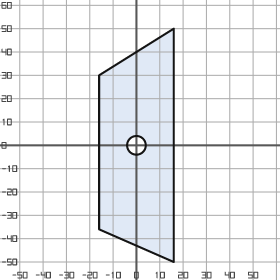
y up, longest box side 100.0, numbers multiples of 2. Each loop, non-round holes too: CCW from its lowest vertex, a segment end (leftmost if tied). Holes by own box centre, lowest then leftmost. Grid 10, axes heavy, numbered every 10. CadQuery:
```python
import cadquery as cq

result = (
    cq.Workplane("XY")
    .moveTo(16.0, -50.0)
    .lineTo(16.0, 50.0)
    .lineTo(-16.0, 30.0)
    .lineTo(-16.0, -36.0)
    .close()
    .moveTo(0.0, 0.0)
    .circle(4.0)
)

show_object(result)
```